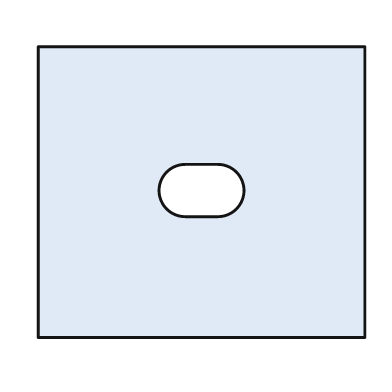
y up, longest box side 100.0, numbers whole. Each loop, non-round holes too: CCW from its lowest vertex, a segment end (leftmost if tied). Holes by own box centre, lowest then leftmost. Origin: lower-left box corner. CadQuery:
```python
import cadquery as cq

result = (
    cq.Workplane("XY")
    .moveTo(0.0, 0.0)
    .lineTo(100.0, 0.0)
    .lineTo(100.0, 89.0)
    .lineTo(0.0, 89.0)
    .close()
    .moveTo(45.0, 37.0)
    .lineTo(55.0, 37.0)
    .threePointArc((63.0, 45.0), (55.0, 53.0))
    .lineTo(45.0, 53.0)
    .threePointArc((37.0, 45.0), (45.0, 37.0))
    .close()
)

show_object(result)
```